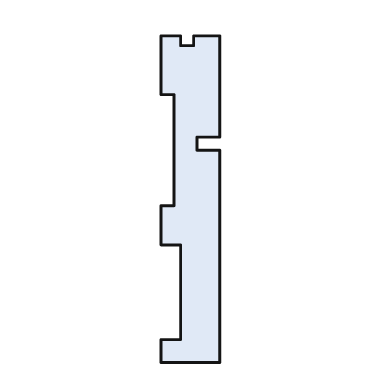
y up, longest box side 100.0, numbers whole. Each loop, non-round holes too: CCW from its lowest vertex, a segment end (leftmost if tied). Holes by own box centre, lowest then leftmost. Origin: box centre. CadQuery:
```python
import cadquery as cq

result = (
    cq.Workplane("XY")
    .moveTo(-9.0, -50.0)
    .lineTo(9.0, -50.0)
    .lineTo(9.0, 15.0)
    .lineTo(2.0, 15.0)
    .lineTo(2.0, 19.0)
    .lineTo(9.0, 19.0)
    .lineTo(9.0, 50.0)
    .lineTo(1.0, 50.0)
    .lineTo(1.0, 47.0)
    .lineTo(-3.0, 47.0)
    .lineTo(-3.0, 50.0)
    .lineTo(-9.0, 50.0)
    .lineTo(-9.0, 32.0)
    .lineTo(-5.0, 32.0)
    .lineTo(-5.0, -2.0)
    .lineTo(-9.0, -2.0)
    .lineTo(-9.0, -14.0)
    .lineTo(-3.0, -14.0)
    .lineTo(-3.0, -43.0)
    .lineTo(-9.0, -43.0)
    .close()
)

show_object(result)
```